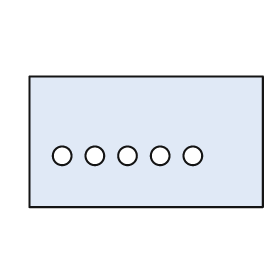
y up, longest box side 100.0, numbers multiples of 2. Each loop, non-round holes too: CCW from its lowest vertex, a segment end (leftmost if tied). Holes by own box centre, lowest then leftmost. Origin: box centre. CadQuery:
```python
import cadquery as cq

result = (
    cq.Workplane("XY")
    .moveTo(-50.0, -28.0)
    .lineTo(50.0, -28.0)
    .lineTo(50.0, 28.0)
    .lineTo(-50.0, 28.0)
    .close()
    .moveTo(-36.0, -6.0)
    .circle(4.0)
    .moveTo(-22.0, -6.0)
    .circle(4.0)
    .moveTo(-8.0, -6.0)
    .circle(4.0)
    .moveTo(6.0, -6.0)
    .circle(4.0)
    .moveTo(20.0, -6.0)
    .circle(4.0)
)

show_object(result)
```